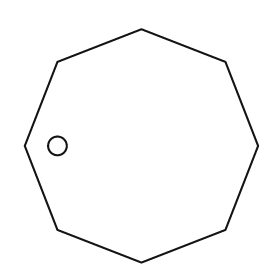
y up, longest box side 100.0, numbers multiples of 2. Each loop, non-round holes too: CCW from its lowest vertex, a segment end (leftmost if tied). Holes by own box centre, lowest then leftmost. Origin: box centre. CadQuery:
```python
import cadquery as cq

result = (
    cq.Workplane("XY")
    .moveTo(0.0, -50.0)
    .lineTo(36.0, -36.0)
    .lineTo(50.0, 0.0)
    .lineTo(36.0, 36.0)
    .lineTo(0.0, 50.0)
    .lineTo(-36.0, 36.0)
    .lineTo(-50.0, 0.0)
    .lineTo(-36.0, -36.0)
    .close()
    .moveTo(-36.0, 0.0)
    .circle(4.0)
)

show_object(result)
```